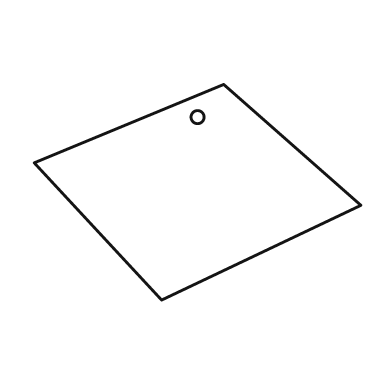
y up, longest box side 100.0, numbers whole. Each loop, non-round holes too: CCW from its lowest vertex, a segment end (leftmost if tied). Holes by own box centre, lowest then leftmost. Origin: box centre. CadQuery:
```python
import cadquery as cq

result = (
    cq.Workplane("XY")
    .moveTo(-11.0, -33.0)
    .lineTo(50.0, -4.0)
    .lineTo(8.0, 33.0)
    .lineTo(-50.0, 9.0)
    .close()
    .moveTo(0.0, 23.0)
    .circle(2.0)
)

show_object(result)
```